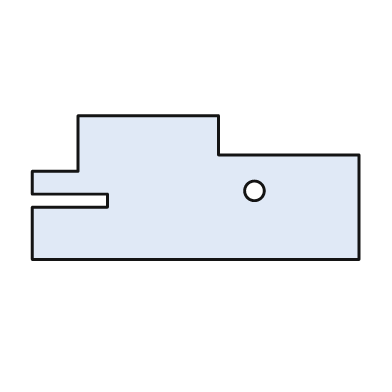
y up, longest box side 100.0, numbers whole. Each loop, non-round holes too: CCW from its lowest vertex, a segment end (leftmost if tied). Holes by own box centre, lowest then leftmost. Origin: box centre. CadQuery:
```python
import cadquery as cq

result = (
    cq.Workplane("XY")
    .moveTo(-50.0, -22.0)
    .lineTo(50.0, -22.0)
    .lineTo(50.0, 10.0)
    .lineTo(7.0, 10.0)
    .lineTo(7.0, 22.0)
    .lineTo(-36.0, 22.0)
    .lineTo(-36.0, 5.0)
    .lineTo(-50.0, 5.0)
    .lineTo(-50.0, -2.0)
    .lineTo(-27.0, -2.0)
    .lineTo(-27.0, -6.0)
    .lineTo(-50.0, -6.0)
    .close()
    .moveTo(18.0, -1.0)
    .circle(3.0)
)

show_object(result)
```